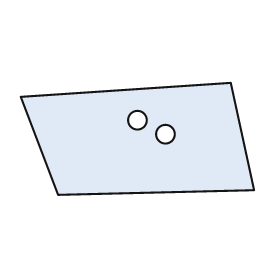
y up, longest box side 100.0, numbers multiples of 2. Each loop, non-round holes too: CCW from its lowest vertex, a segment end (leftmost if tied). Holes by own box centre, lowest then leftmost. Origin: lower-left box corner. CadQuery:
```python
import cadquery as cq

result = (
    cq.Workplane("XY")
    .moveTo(16.0, 0.0)
    .lineTo(100.0, 2.0)
    .lineTo(90.0, 48.0)
    .lineTo(0.0, 42.0)
    .close()
    .moveTo(62.0, 26.0)
    .circle(4.0)
    .moveTo(50.0, 32.0)
    .circle(4.0)
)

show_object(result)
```